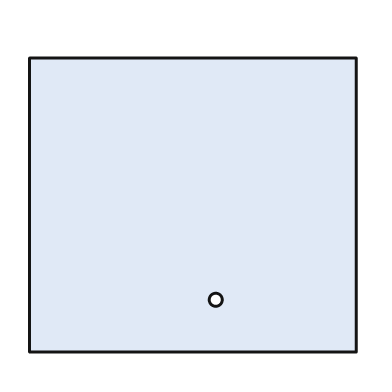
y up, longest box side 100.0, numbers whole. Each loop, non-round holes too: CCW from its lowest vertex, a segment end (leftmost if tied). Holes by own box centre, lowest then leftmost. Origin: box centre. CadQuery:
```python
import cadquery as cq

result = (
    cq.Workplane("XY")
    .moveTo(-50.0, -45.0)
    .lineTo(50.0, -45.0)
    .lineTo(50.0, 45.0)
    .lineTo(-50.0, 45.0)
    .close()
    .moveTo(7.0, -29.0)
    .circle(2.0)
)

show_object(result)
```